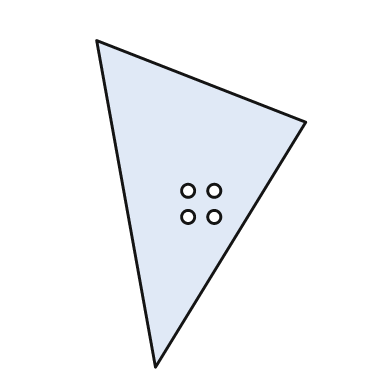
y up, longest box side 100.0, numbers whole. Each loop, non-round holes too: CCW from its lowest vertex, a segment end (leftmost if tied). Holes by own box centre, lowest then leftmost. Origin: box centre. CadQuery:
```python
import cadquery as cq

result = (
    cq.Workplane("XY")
    .moveTo(-14.0, -50.0)
    .lineTo(32.0, 25.0)
    .lineTo(-32.0, 50.0)
    .close()
    .moveTo(-4.0, -4.0)
    .circle(2.0)
    .moveTo(4.0, -4.0)
    .circle(2.0)
    .moveTo(-4.0, 4.0)
    .circle(2.0)
    .moveTo(4.0, 4.0)
    .circle(2.0)
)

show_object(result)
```